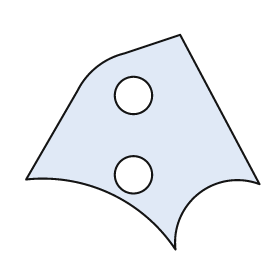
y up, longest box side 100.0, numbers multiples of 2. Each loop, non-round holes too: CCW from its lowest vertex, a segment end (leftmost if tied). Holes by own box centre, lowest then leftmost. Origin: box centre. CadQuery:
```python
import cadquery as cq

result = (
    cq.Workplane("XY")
    .moveTo(14.0, -46.0)
    .threePointArc((24.0, -22.0), (50.0, -18.0))
    .lineTo(16.0, 46.0)
    .lineTo(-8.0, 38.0)
    .threePointArc((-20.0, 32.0), (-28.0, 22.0))
    .lineTo(-50.0, -16.0)
    .threePointArc((-14.0, -22.0), (14.0, -46.0))
    .close()
    .moveTo(-4.0, -14.0)
    .circle(8.0)
    .moveTo(-4.0, 20.0)
    .circle(8.0)
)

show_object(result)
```